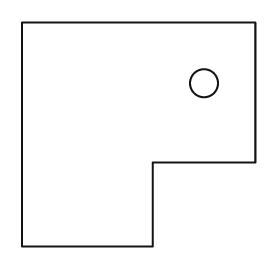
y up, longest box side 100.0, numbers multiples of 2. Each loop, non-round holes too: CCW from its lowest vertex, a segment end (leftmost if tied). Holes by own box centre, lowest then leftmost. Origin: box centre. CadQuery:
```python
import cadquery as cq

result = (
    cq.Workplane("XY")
    .moveTo(-50.0, -48.0)
    .lineTo(6.0, -48.0)
    .lineTo(6.0, -12.0)
    .lineTo(50.0, -12.0)
    .lineTo(50.0, 48.0)
    .lineTo(-50.0, 48.0)
    .close()
    .moveTo(28.0, 22.0)
    .circle(6.0)
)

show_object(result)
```